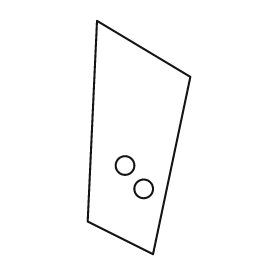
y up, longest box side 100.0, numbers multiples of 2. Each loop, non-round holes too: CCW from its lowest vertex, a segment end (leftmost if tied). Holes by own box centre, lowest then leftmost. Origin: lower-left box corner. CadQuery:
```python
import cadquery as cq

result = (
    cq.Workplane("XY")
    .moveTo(28.0, 0.0)
    .lineTo(44.0, 76.0)
    .lineTo(4.0, 100.0)
    .lineTo(0.0, 14.0)
    .close()
    .moveTo(24.0, 28.0)
    .circle(4.0)
    .moveTo(16.0, 38.0)
    .circle(4.0)
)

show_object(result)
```